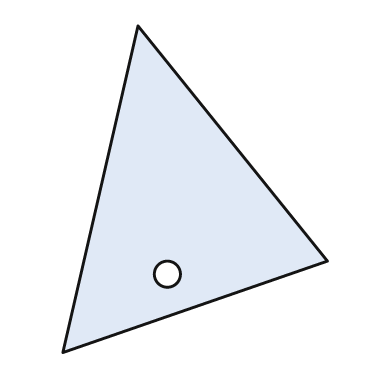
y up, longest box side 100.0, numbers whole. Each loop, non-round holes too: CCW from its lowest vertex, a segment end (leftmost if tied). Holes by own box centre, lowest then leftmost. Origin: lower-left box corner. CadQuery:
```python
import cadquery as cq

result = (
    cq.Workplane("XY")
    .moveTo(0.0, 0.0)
    .lineTo(81.0, 28.0)
    .lineTo(23.0, 100.0)
    .close()
    .moveTo(32.0, 24.0)
    .circle(4.0)
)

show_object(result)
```